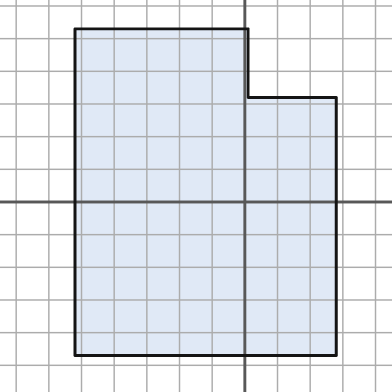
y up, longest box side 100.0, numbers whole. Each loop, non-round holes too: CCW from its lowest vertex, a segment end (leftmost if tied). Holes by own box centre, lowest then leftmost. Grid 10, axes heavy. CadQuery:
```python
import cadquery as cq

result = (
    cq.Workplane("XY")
    .moveTo(-52.0, -47.0)
    .lineTo(28.0, -47.0)
    .lineTo(28.0, 32.0)
    .lineTo(1.0, 32.0)
    .lineTo(1.0, 53.0)
    .lineTo(-52.0, 53.0)
    .close()
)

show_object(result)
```